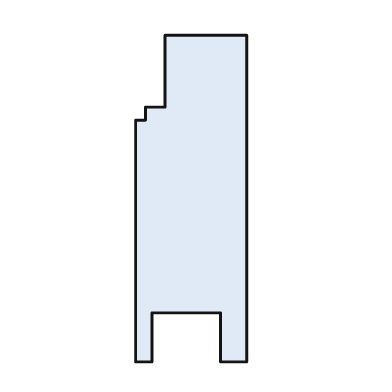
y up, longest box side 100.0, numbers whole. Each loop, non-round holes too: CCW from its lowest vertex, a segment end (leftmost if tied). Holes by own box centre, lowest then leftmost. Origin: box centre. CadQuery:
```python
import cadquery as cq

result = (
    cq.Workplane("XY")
    .moveTo(-17.0, -50.0)
    .lineTo(-12.0, -50.0)
    .lineTo(-12.0, -35.0)
    .lineTo(9.0, -35.0)
    .lineTo(9.0, -50.0)
    .lineTo(17.0, -50.0)
    .lineTo(17.0, 50.0)
    .lineTo(-8.0, 50.0)
    .lineTo(-8.0, 28.0)
    .lineTo(-14.0, 28.0)
    .lineTo(-14.0, 24.0)
    .lineTo(-17.0, 24.0)
    .close()
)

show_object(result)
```